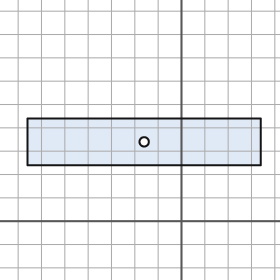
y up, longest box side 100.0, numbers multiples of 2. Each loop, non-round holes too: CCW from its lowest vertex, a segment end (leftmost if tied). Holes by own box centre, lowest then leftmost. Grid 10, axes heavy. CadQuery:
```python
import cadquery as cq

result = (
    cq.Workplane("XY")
    .moveTo(-66.0, 24.0)
    .lineTo(34.0, 24.0)
    .lineTo(34.0, 44.0)
    .lineTo(-66.0, 44.0)
    .close()
    .moveTo(-16.0, 34.0)
    .circle(2.0)
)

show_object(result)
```